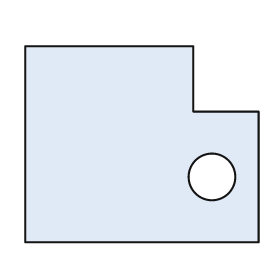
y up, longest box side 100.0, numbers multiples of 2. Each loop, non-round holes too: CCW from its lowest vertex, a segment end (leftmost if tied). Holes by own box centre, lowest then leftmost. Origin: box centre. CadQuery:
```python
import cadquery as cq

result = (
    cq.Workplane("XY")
    .moveTo(-50.0, -42.0)
    .lineTo(50.0, -42.0)
    .lineTo(50.0, 14.0)
    .lineTo(22.0, 14.0)
    .lineTo(22.0, 42.0)
    .lineTo(-50.0, 42.0)
    .close()
    .moveTo(30.0, -14.0)
    .circle(10.0)
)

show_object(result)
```